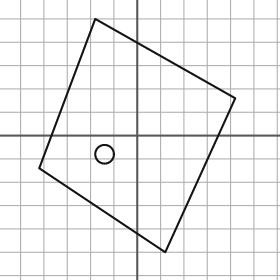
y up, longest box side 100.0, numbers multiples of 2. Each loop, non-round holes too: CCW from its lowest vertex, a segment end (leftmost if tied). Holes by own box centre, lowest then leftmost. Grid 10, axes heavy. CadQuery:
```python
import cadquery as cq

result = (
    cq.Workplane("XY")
    .moveTo(12.0, -50.0)
    .lineTo(42.0, 16.0)
    .lineTo(-18.0, 50.0)
    .lineTo(-42.0, -14.0)
    .close()
    .moveTo(-14.0, -8.0)
    .circle(4.0)
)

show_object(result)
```